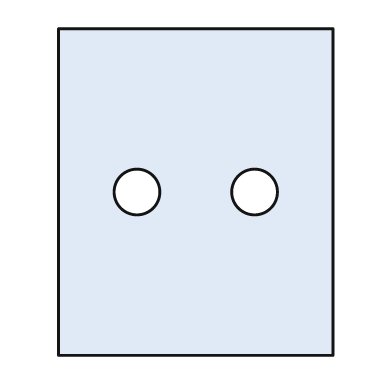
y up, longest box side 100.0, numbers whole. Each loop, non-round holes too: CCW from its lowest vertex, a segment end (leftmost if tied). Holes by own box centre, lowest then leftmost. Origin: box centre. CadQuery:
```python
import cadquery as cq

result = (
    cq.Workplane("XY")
    .moveTo(-42.0, -50.0)
    .lineTo(42.0, -50.0)
    .lineTo(42.0, 50.0)
    .lineTo(-42.0, 50.0)
    .close()
    .moveTo(-18.0, 0.0)
    .circle(7.0)
    .moveTo(18.0, 0.0)
    .circle(7.0)
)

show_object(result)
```